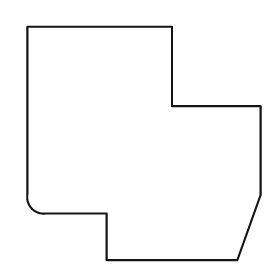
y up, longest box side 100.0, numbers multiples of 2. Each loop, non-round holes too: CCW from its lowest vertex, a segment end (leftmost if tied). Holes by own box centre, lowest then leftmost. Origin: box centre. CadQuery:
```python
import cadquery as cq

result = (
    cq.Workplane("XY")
    .moveTo(-16.0, -50.0)
    .lineTo(40.0, -50.0)
    .lineTo(50.0, -22.0)
    .lineTo(50.0, 16.0)
    .lineTo(12.0, 16.0)
    .lineTo(12.0, 50.0)
    .lineTo(-50.0, 50.0)
    .lineTo(-50.0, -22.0)
    .threePointArc((-48.0, -28.0), (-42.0, -30.0))
    .lineTo(-16.0, -30.0)
    .close()
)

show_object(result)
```